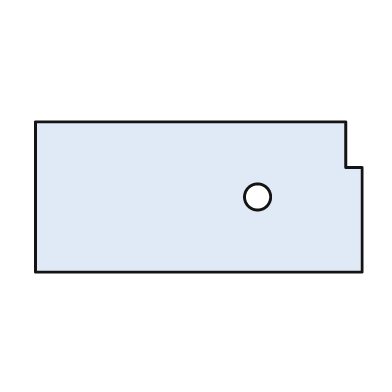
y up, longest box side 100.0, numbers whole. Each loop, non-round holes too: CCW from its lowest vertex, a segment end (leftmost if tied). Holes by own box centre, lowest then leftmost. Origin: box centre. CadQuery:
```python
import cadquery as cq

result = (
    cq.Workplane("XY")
    .moveTo(-50.0, -23.0)
    .lineTo(50.0, -23.0)
    .lineTo(50.0, 9.0)
    .lineTo(45.0, 9.0)
    .lineTo(45.0, 23.0)
    .lineTo(-50.0, 23.0)
    .close()
    .moveTo(18.0, 0.0)
    .circle(4.0)
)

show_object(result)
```